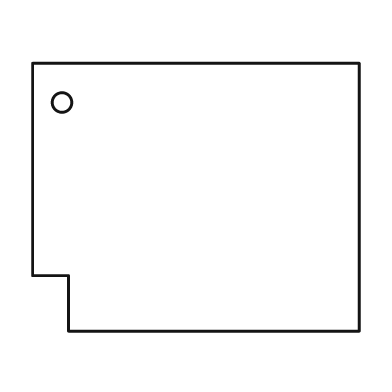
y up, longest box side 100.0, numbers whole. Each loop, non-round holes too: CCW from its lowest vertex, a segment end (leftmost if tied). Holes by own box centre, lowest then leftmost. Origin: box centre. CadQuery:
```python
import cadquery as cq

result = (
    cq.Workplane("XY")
    .moveTo(-39.0, -41.0)
    .lineTo(50.0, -41.0)
    .lineTo(50.0, 41.0)
    .lineTo(-50.0, 41.0)
    .lineTo(-50.0, -24.0)
    .lineTo(-39.0, -24.0)
    .close()
    .moveTo(-41.0, 29.0)
    .circle(3.0)
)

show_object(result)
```